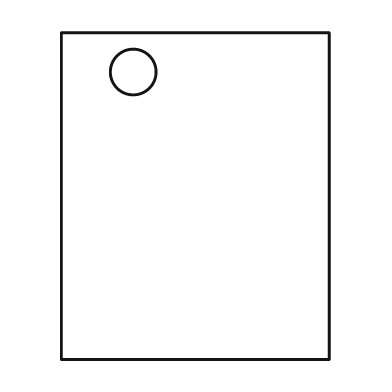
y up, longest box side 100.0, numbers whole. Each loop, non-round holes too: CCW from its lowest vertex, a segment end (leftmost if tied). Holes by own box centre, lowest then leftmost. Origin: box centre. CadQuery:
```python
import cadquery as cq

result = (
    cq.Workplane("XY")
    .moveTo(-41.0, -50.0)
    .lineTo(41.0, -50.0)
    .lineTo(41.0, 50.0)
    .lineTo(-41.0, 50.0)
    .close()
    .moveTo(-19.0, 38.0)
    .circle(7.0)
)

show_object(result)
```